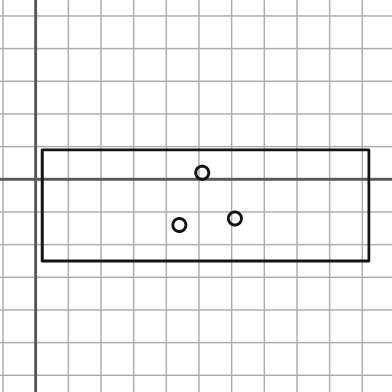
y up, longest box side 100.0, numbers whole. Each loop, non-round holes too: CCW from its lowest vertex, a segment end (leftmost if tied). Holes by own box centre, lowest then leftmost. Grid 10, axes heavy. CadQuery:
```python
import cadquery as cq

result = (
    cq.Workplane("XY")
    .moveTo(2.0, -25.0)
    .lineTo(102.0, -25.0)
    .lineTo(102.0, 9.0)
    .lineTo(2.0, 9.0)
    .close()
    .moveTo(44.0, -14.0)
    .circle(2.0)
    .moveTo(61.0, -12.0)
    .circle(2.0)
    .moveTo(51.0, 2.0)
    .circle(2.0)
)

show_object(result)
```